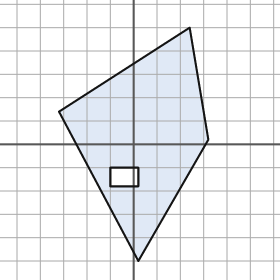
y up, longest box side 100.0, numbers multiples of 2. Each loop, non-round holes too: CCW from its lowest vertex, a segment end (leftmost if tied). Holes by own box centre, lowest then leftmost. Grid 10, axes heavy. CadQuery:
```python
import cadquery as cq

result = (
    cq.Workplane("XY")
    .moveTo(2.0, -50.0)
    .lineTo(32.0, 2.0)
    .lineTo(24.0, 50.0)
    .lineTo(-32.0, 14.0)
    .close()
    .moveTo(-10.0, -18.0)
    .lineTo(2.0, -18.0)
    .lineTo(2.0, -10.0)
    .lineTo(-10.0, -10.0)
    .close()
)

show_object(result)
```